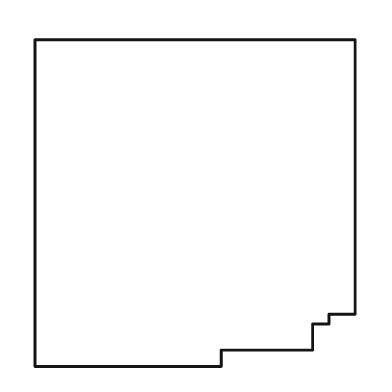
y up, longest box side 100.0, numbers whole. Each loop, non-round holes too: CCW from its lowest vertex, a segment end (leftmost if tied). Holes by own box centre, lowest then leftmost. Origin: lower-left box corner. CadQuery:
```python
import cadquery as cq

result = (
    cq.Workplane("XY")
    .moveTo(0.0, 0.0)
    .lineTo(57.0, 0.0)
    .lineTo(57.0, 5.0)
    .lineTo(85.0, 5.0)
    .lineTo(85.0, 13.0)
    .lineTo(90.0, 13.0)
    .lineTo(90.0, 16.0)
    .lineTo(98.0, 16.0)
    .lineTo(98.0, 100.0)
    .lineTo(0.0, 100.0)
    .close()
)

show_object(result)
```